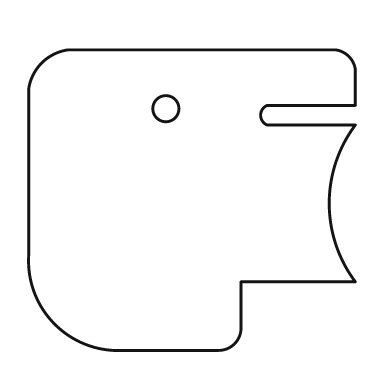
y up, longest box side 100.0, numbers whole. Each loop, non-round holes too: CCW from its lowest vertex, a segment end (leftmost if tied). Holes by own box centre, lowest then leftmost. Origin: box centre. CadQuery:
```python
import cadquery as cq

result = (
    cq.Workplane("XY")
    .moveTo(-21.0, -46.0)
    .lineTo(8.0, -46.0)
    .threePointArc((13.0, -44.0), (15.0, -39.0))
    .lineTo(15.0, -25.0)
    .lineTo(50.0, -25.0)
    .threePointArc((42.0, -1.0), (50.0, 23.0))
    .lineTo(23.0, 23.0)
    .threePointArc((21.0, 26.0), (23.0, 29.0))
    .lineTo(50.0, 29.0)
    .lineTo(50.0, 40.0)
    .threePointArc((48.0, 44.0), (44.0, 46.0))
    .lineTo(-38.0, 46.0)
    .threePointArc((-46.0, 42.0), (-50.0, 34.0))
    .lineTo(-50.0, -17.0)
    .threePointArc((-42.0, -38.0), (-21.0, -46.0))
    .close()
    .moveTo(-8.0, 28.0)
    .circle(4.0)
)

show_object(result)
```